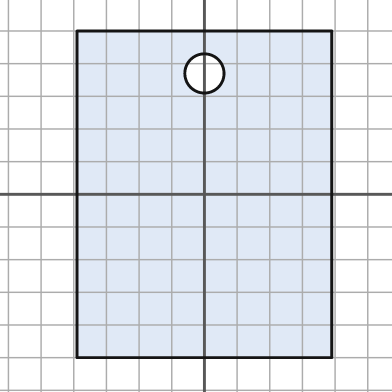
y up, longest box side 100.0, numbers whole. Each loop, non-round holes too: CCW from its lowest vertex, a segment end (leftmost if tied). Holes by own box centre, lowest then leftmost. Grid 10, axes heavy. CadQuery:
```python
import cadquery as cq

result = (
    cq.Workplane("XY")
    .moveTo(-39.0, -50.0)
    .lineTo(39.0, -50.0)
    .lineTo(39.0, 50.0)
    .lineTo(-39.0, 50.0)
    .close()
    .moveTo(0.0, 37.0)
    .circle(6.0)
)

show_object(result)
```